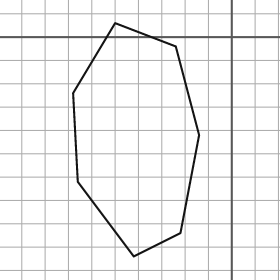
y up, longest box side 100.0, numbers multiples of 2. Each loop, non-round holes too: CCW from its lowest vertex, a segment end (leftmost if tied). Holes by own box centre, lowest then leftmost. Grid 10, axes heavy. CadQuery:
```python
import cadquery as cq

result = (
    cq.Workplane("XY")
    .moveTo(-42.0, -94.0)
    .lineTo(-22.0, -84.0)
    .lineTo(-14.0, -42.0)
    .lineTo(-24.0, -4.0)
    .lineTo(-50.0, 6.0)
    .lineTo(-68.0, -24.0)
    .lineTo(-66.0, -62.0)
    .close()
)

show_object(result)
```